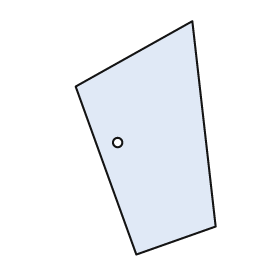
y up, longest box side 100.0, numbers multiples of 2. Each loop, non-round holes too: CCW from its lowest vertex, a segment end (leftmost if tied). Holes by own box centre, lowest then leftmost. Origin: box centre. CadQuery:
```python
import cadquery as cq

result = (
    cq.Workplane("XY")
    .moveTo(-4.0, -50.0)
    .lineTo(30.0, -38.0)
    .lineTo(20.0, 50.0)
    .lineTo(-30.0, 22.0)
    .close()
    .moveTo(-12.0, -2.0)
    .circle(2.0)
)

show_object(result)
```